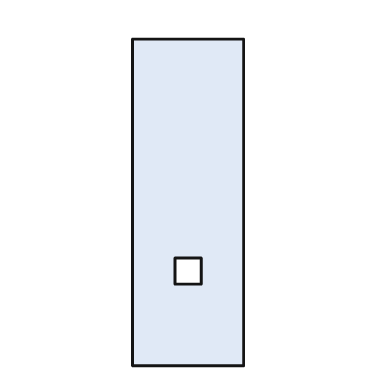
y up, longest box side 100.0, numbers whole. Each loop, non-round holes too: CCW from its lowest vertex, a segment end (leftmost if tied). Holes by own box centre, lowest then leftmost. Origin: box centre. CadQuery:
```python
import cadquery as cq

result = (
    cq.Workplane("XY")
    .moveTo(-17.0, -50.0)
    .lineTo(17.0, -50.0)
    .lineTo(17.0, 50.0)
    .lineTo(-17.0, 50.0)
    .close()
    .moveTo(-4.0, -25.0)
    .lineTo(4.0, -25.0)
    .lineTo(4.0, -17.0)
    .lineTo(-4.0, -17.0)
    .close()
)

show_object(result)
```